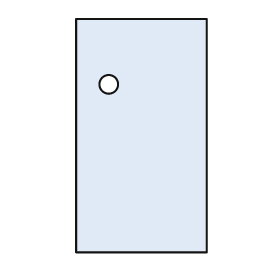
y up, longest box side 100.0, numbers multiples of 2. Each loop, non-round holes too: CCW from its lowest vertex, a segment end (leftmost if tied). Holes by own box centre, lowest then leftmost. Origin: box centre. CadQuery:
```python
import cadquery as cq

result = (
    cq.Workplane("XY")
    .moveTo(-28.0, -50.0)
    .lineTo(28.0, -50.0)
    .lineTo(28.0, 50.0)
    .lineTo(-28.0, 50.0)
    .close()
    .moveTo(-14.0, 22.0)
    .circle(4.0)
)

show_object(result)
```